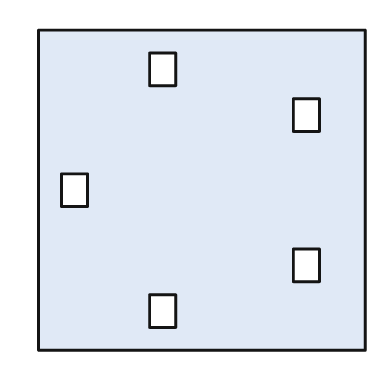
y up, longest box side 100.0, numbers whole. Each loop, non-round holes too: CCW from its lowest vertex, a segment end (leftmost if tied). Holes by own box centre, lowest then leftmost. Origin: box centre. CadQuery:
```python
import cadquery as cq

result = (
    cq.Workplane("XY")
    .moveTo(-50.0, -49.0)
    .lineTo(50.0, -49.0)
    .lineTo(50.0, 49.0)
    .lineTo(-50.0, 49.0)
    .close()
    .moveTo(-16.0, -42.0)
    .lineTo(-8.0, -42.0)
    .lineTo(-8.0, -32.0)
    .lineTo(-16.0, -32.0)
    .close()
    .moveTo(28.0, -28.0)
    .lineTo(36.0, -28.0)
    .lineTo(36.0, -18.0)
    .lineTo(28.0, -18.0)
    .close()
    .moveTo(-43.0, -5.0)
    .lineTo(-35.0, -5.0)
    .lineTo(-35.0, 5.0)
    .lineTo(-43.0, 5.0)
    .close()
    .moveTo(28.0, 18.0)
    .lineTo(36.0, 18.0)
    .lineTo(36.0, 28.0)
    .lineTo(28.0, 28.0)
    .close()
    .moveTo(-16.0, 32.0)
    .lineTo(-8.0, 32.0)
    .lineTo(-8.0, 42.0)
    .lineTo(-16.0, 42.0)
    .close()
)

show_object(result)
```